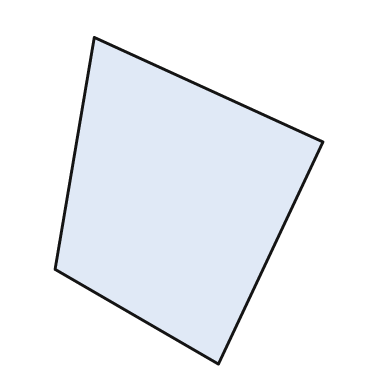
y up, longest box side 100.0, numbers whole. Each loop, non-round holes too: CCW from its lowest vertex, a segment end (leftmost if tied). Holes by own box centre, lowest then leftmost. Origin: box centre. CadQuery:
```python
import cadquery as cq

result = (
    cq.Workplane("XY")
    .moveTo(9.0, -50.0)
    .lineTo(41.0, 18.0)
    .lineTo(-29.0, 50.0)
    .lineTo(-41.0, -21.0)
    .close()
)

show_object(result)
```